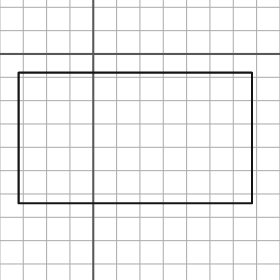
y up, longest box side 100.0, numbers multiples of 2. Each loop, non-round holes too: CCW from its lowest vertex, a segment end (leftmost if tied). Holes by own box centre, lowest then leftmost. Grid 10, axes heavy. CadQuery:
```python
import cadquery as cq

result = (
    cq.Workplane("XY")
    .moveTo(-32.0, -64.0)
    .lineTo(68.0, -64.0)
    .lineTo(68.0, -8.0)
    .lineTo(-32.0, -8.0)
    .close()
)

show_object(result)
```